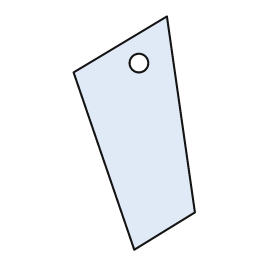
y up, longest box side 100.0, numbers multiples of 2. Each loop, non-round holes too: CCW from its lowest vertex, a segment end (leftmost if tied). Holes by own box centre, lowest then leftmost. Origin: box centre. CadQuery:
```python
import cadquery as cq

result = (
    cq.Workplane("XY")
    .moveTo(0.0, -50.0)
    .lineTo(26.0, -34.0)
    .lineTo(14.0, 50.0)
    .lineTo(-26.0, 26.0)
    .close()
    .moveTo(2.0, 30.0)
    .circle(4.0)
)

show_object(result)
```